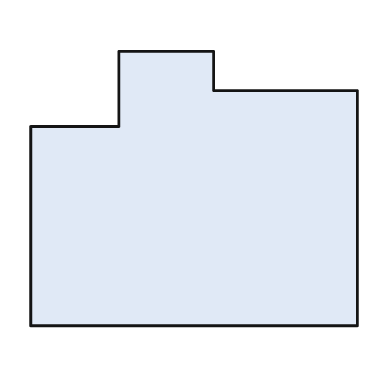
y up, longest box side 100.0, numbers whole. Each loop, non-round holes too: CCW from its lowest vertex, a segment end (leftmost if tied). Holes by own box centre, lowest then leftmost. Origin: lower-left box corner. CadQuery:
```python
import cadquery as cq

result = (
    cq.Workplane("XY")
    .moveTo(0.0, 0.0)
    .lineTo(100.0, 0.0)
    .lineTo(100.0, 72.0)
    .lineTo(56.0, 72.0)
    .lineTo(56.0, 84.0)
    .lineTo(27.0, 84.0)
    .lineTo(27.0, 61.0)
    .lineTo(0.0, 61.0)
    .close()
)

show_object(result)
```